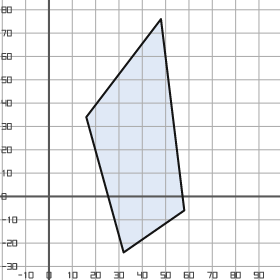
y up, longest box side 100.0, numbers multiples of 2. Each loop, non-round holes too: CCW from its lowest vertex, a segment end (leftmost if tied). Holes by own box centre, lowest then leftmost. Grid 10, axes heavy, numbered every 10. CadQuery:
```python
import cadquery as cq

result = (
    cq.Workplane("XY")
    .moveTo(32.0, -24.0)
    .lineTo(58.0, -6.0)
    .lineTo(48.0, 76.0)
    .lineTo(16.0, 34.0)
    .close()
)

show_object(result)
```